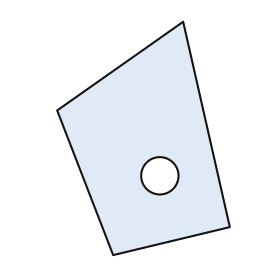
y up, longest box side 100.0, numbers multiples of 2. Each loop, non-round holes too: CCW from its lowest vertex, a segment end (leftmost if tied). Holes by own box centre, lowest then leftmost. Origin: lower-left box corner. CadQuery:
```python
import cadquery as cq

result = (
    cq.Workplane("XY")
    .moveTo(24.0, 0.0)
    .lineTo(74.0, 12.0)
    .lineTo(54.0, 100.0)
    .lineTo(0.0, 62.0)
    .close()
    .moveTo(44.0, 34.0)
    .circle(8.0)
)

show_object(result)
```